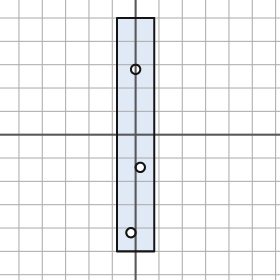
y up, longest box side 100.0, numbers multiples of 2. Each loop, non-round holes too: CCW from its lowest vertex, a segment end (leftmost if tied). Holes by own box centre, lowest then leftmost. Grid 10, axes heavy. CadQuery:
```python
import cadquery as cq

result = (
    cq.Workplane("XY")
    .moveTo(-8.0, -50.0)
    .lineTo(8.0, -50.0)
    .lineTo(8.0, 50.0)
    .lineTo(-8.0, 50.0)
    .close()
    .moveTo(-2.0, -42.0)
    .circle(2.0)
    .moveTo(2.0, -14.0)
    .circle(2.0)
    .moveTo(0.0, 28.0)
    .circle(2.0)
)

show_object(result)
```